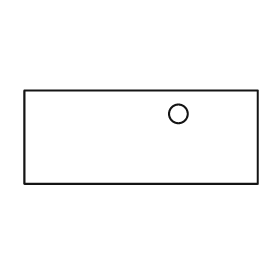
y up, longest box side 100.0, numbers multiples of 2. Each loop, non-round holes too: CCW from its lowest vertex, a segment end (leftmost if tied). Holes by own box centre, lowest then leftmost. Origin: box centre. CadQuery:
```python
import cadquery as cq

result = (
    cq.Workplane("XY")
    .moveTo(-50.0, -20.0)
    .lineTo(50.0, -20.0)
    .lineTo(50.0, 20.0)
    .lineTo(-50.0, 20.0)
    .close()
    .moveTo(16.0, 10.0)
    .circle(4.0)
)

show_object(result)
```